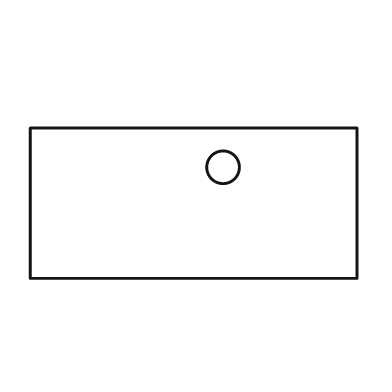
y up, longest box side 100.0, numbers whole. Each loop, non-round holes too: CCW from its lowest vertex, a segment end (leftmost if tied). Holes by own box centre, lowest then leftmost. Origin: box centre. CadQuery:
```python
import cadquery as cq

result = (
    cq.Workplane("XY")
    .moveTo(-50.0, -23.0)
    .lineTo(50.0, -23.0)
    .lineTo(50.0, 23.0)
    .lineTo(-50.0, 23.0)
    .close()
    .moveTo(9.0, 11.0)
    .circle(5.0)
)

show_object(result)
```